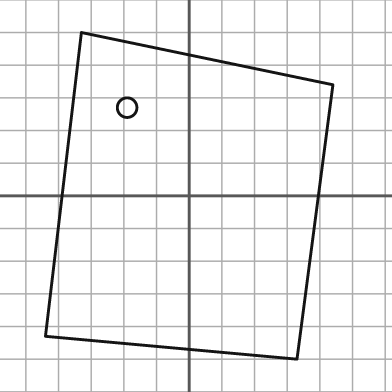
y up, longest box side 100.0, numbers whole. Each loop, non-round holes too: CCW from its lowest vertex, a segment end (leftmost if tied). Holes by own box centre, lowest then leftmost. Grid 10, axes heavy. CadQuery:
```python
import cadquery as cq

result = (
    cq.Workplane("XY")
    .moveTo(33.0, -50.0)
    .lineTo(44.0, 34.0)
    .lineTo(-33.0, 50.0)
    .lineTo(-44.0, -43.0)
    .close()
    .moveTo(-19.0, 27.0)
    .circle(3.0)
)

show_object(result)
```